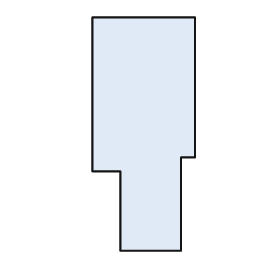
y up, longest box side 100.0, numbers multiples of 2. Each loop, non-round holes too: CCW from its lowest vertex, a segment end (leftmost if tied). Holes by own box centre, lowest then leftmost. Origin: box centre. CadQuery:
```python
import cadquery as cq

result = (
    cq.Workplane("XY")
    .moveTo(-10.0, -50.0)
    .lineTo(16.0, -50.0)
    .lineTo(16.0, -10.0)
    .lineTo(22.0, -10.0)
    .lineTo(22.0, 50.0)
    .lineTo(-22.0, 50.0)
    .lineTo(-22.0, -16.0)
    .lineTo(-10.0, -16.0)
    .close()
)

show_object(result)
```